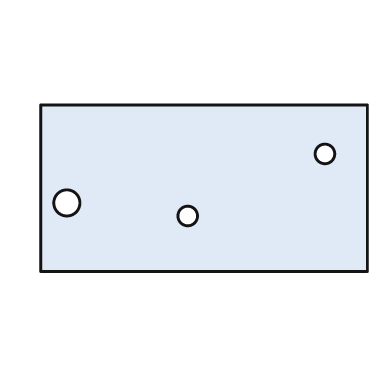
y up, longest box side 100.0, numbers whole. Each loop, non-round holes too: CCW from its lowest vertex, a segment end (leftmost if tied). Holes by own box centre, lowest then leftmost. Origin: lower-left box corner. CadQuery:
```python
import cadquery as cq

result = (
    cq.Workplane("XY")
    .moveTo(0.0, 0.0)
    .lineTo(100.0, 0.0)
    .lineTo(100.0, 51.0)
    .lineTo(0.0, 51.0)
    .close()
    .moveTo(45.0, 17.0)
    .circle(3.0)
    .moveTo(8.0, 21.0)
    .circle(4.0)
    .moveTo(87.0, 36.0)
    .circle(3.0)
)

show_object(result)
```